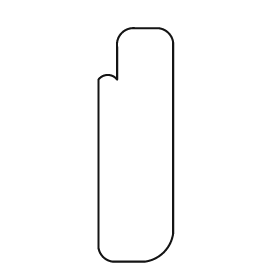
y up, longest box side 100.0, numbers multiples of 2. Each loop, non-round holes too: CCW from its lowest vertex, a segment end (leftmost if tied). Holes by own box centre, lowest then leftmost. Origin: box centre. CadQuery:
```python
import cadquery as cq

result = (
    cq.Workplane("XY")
    .moveTo(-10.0, -50.0)
    .lineTo(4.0, -50.0)
    .threePointArc((12.0, -46.0), (16.0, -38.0))
    .lineTo(16.0, 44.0)
    .threePointArc((14.0, 48.0), (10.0, 50.0))
    .lineTo(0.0, 50.0)
    .threePointArc((-6.0, 48.0), (-8.0, 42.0))
    .lineTo(-8.0, 28.0)
    .threePointArc((-12.0, 30.0), (-16.0, 28.0))
    .lineTo(-16.0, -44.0)
    .threePointArc((-14.0, -48.0), (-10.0, -50.0))
    .close()
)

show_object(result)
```